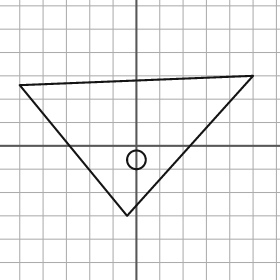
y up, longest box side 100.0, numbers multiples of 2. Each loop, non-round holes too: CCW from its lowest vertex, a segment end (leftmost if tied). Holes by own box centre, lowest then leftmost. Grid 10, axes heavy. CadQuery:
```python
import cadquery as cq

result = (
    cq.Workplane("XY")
    .moveTo(-4.0, -30.0)
    .lineTo(50.0, 30.0)
    .lineTo(-50.0, 26.0)
    .close()
    .moveTo(0.0, -6.0)
    .circle(4.0)
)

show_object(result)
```